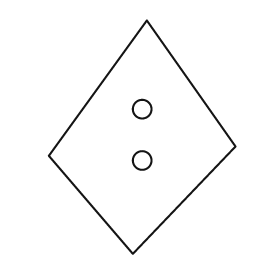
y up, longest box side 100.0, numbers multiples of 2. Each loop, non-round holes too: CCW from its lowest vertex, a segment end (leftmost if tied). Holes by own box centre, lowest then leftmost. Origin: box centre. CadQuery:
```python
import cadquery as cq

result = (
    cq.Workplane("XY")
    .moveTo(-4.0, -50.0)
    .lineTo(40.0, -4.0)
    .lineTo(2.0, 50.0)
    .lineTo(-40.0, -8.0)
    .close()
    .moveTo(0.0, -10.0)
    .circle(4.0)
    .moveTo(0.0, 12.0)
    .circle(4.0)
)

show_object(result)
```